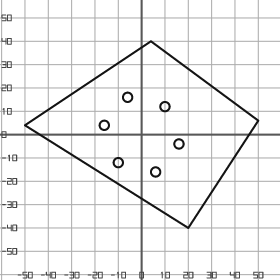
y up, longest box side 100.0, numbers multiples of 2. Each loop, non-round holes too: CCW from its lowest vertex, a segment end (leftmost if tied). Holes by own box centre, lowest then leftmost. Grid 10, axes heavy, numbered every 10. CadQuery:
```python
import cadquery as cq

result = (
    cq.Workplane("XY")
    .moveTo(20.0, -40.0)
    .lineTo(50.0, 6.0)
    .lineTo(4.0, 40.0)
    .lineTo(-50.0, 4.0)
    .close()
    .moveTo(6.0, -16.0)
    .circle(2.0)
    .moveTo(-10.0, -12.0)
    .circle(2.0)
    .moveTo(16.0, -4.0)
    .circle(2.0)
    .moveTo(-16.0, 4.0)
    .circle(2.0)
    .moveTo(10.0, 12.0)
    .circle(2.0)
    .moveTo(-6.0, 16.0)
    .circle(2.0)
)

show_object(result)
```